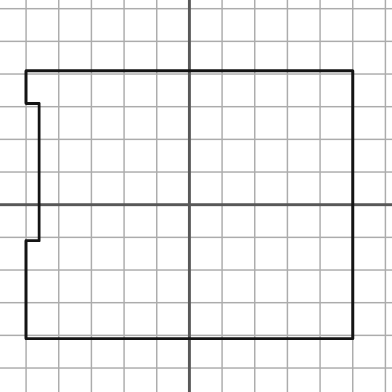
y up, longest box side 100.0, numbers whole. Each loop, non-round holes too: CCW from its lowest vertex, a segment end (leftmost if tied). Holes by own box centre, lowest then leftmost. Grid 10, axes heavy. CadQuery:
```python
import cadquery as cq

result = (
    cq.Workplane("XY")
    .moveTo(-50.0, -41.0)
    .lineTo(50.0, -41.0)
    .lineTo(50.0, 41.0)
    .lineTo(-50.0, 41.0)
    .lineTo(-50.0, 31.0)
    .lineTo(-46.0, 31.0)
    .lineTo(-46.0, -11.0)
    .lineTo(-50.0, -11.0)
    .close()
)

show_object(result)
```